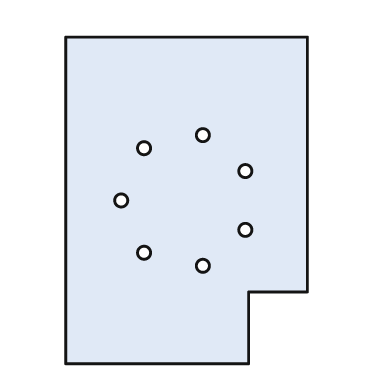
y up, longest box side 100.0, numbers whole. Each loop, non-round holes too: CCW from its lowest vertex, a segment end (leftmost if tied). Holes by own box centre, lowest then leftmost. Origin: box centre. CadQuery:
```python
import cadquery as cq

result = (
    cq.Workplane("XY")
    .moveTo(-37.0, -50.0)
    .lineTo(19.0, -50.0)
    .lineTo(19.0, -28.0)
    .lineTo(37.0, -28.0)
    .lineTo(37.0, 50.0)
    .lineTo(-37.0, 50.0)
    .close()
    .moveTo(5.0, -20.0)
    .circle(2.0)
    .moveTo(-13.0, -16.0)
    .circle(2.0)
    .moveTo(18.0, -9.0)
    .circle(2.0)
    .moveTo(-20.0, 0.0)
    .circle(2.0)
    .moveTo(18.0, 9.0)
    .circle(2.0)
    .moveTo(-13.0, 16.0)
    .circle(2.0)
    .moveTo(5.0, 20.0)
    .circle(2.0)
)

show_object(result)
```